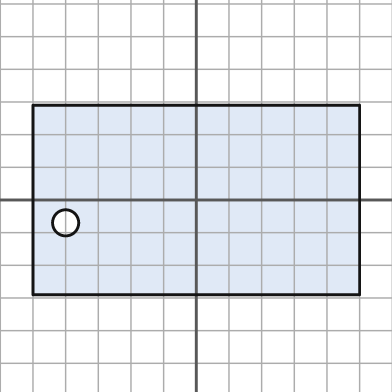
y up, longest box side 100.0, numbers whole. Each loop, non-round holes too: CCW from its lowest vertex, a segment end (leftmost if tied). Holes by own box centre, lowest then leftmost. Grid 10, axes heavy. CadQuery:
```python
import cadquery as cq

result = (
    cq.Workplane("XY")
    .moveTo(-50.0, -29.0)
    .lineTo(50.0, -29.0)
    .lineTo(50.0, 29.0)
    .lineTo(-50.0, 29.0)
    .close()
    .moveTo(-40.0, -7.0)
    .circle(4.0)
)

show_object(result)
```